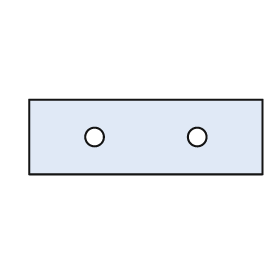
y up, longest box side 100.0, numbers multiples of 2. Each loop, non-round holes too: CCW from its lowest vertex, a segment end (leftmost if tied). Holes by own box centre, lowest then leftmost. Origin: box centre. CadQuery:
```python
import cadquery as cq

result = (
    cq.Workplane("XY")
    .moveTo(-50.0, -16.0)
    .lineTo(50.0, -16.0)
    .lineTo(50.0, 16.0)
    .lineTo(-50.0, 16.0)
    .close()
    .moveTo(-22.0, 0.0)
    .circle(4.0)
    .moveTo(22.0, 0.0)
    .circle(4.0)
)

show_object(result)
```